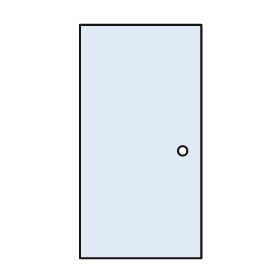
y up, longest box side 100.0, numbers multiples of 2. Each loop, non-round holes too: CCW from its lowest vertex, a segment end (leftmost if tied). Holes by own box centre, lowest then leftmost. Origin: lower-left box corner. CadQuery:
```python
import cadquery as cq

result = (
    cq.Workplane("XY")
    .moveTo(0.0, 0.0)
    .lineTo(52.0, 0.0)
    .lineTo(52.0, 100.0)
    .lineTo(0.0, 100.0)
    .close()
    .moveTo(44.0, 46.0)
    .circle(2.0)
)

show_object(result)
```